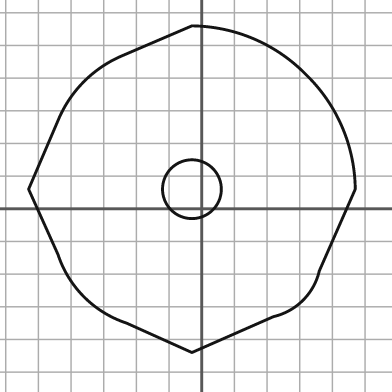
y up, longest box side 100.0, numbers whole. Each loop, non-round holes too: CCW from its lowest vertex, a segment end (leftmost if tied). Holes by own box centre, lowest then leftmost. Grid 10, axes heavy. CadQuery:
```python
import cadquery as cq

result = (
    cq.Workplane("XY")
    .moveTo(-3.0, -44.0)
    .lineTo(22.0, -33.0)
    .threePointArc((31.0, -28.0), (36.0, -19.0))
    .lineTo(47.0, 6.0)
    .threePointArc((43.0, 25.0), (32.0, 41.0))
    .threePointArc((16.0, 52.0), (-3.0, 56.0))
    .lineTo(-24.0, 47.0)
    .threePointArc((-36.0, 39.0), (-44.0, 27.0))
    .lineTo(-53.0, 6.0)
    .lineTo(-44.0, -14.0)
    .threePointArc((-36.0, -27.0), (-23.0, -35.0))
    .close()
    .moveTo(-3.0, 6.0)
    .circle(9.0)
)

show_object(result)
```